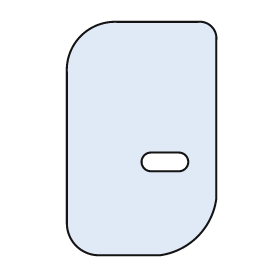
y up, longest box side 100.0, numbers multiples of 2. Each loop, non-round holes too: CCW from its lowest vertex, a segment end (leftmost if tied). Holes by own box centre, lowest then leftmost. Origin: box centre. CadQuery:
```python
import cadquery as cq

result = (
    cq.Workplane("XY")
    .moveTo(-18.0, -50.0)
    .lineTo(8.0, -50.0)
    .threePointArc((24.0, -42.0), (32.0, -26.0))
    .lineTo(32.0, 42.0)
    .threePointArc((30.0, 48.0), (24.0, 50.0))
    .lineTo(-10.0, 50.0)
    .threePointArc((-26.0, 44.0), (-32.0, 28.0))
    .lineTo(-32.0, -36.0)
    .threePointArc((-28.0, -46.0), (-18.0, -50.0))
    .close()
    .moveTo(4.0, -14.0)
    .lineTo(16.0, -14.0)
    .threePointArc((20.0, -10.0), (16.0, -6.0))
    .lineTo(4.0, -6.0)
    .threePointArc((0.0, -10.0), (4.0, -14.0))
    .close()
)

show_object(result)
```